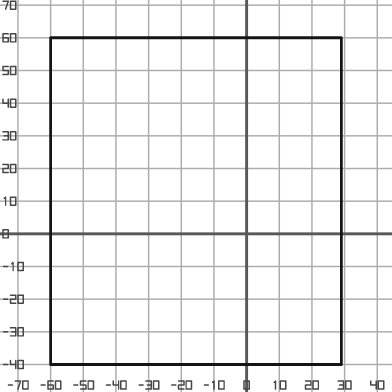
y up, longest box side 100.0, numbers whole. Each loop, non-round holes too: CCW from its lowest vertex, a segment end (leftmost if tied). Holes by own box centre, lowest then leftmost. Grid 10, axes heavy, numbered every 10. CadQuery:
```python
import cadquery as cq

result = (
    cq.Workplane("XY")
    .moveTo(-60.0, -40.0)
    .lineTo(29.0, -40.0)
    .lineTo(29.0, 60.0)
    .lineTo(-60.0, 60.0)
    .close()
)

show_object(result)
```